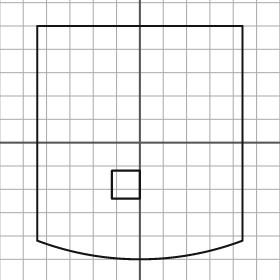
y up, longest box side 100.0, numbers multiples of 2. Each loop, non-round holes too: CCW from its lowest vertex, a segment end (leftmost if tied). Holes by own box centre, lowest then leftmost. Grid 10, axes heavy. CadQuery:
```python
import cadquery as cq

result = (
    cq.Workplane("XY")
    .moveTo(-44.0, -42.0)
    .threePointArc((0.0, -50.0), (44.0, -42.0))
    .lineTo(44.0, 50.0)
    .lineTo(-44.0, 50.0)
    .close()
    .moveTo(-12.0, -24.0)
    .lineTo(0.0, -24.0)
    .lineTo(0.0, -12.0)
    .lineTo(-12.0, -12.0)
    .close()
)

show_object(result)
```